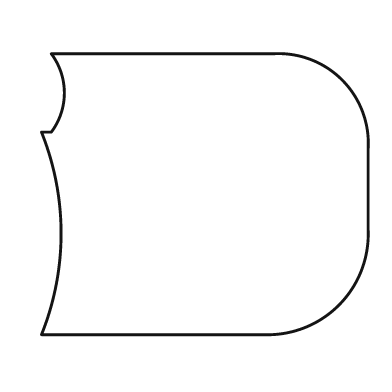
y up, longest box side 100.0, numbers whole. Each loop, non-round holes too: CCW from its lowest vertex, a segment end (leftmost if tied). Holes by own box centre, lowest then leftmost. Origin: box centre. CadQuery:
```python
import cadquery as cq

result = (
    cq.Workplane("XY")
    .moveTo(-50.0, -43.0)
    .lineTo(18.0, -43.0)
    .threePointArc((41.0, -34.0), (50.0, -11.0))
    .lineTo(50.0, 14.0)
    .threePointArc((42.0, 35.0), (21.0, 43.0))
    .lineTo(-47.0, 43.0)
    .threePointArc((-43.0, 31.0), (-47.0, 19.0))
    .lineTo(-50.0, 19.0)
    .threePointArc((-44.0, -12.0), (-50.0, -43.0))
    .close()
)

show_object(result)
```